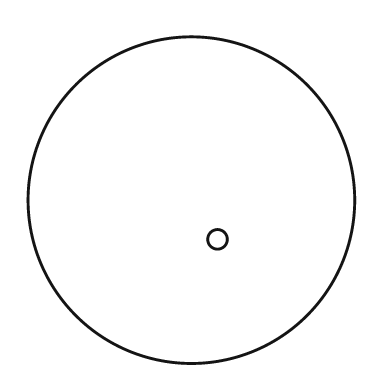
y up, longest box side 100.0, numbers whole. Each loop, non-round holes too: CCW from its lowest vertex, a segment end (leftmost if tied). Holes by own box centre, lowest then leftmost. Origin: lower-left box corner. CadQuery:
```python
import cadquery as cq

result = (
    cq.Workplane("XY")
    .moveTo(50.0, 50.0)
    .circle(50.0)
    .moveTo(58.0, 38.0)
    .circle(3.0)
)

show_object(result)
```